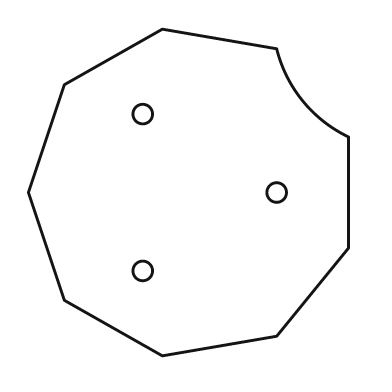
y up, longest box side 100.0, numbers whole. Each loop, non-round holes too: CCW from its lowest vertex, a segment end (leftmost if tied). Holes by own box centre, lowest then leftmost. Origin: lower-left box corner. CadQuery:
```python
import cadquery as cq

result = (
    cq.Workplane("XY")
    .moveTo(41.0, 0.0)
    .lineTo(76.0, 6.0)
    .lineTo(98.0, 33.0)
    .lineTo(98.0, 67.0)
    .threePointArc((84.0, 78.0), (76.0, 94.0))
    .lineTo(41.0, 100.0)
    .lineTo(11.0, 83.0)
    .lineTo(0.0, 50.0)
    .lineTo(11.0, 17.0)
    .close()
    .moveTo(35.0, 26.0)
    .circle(3.0)
    .moveTo(76.0, 50.0)
    .circle(3.0)
    .moveTo(35.0, 74.0)
    .circle(3.0)
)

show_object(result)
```